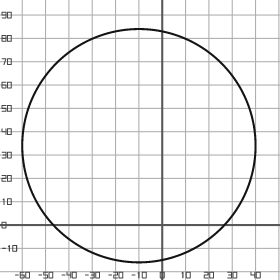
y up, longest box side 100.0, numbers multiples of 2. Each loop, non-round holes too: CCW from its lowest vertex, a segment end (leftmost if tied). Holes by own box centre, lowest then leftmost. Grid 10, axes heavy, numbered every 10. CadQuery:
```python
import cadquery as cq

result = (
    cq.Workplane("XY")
    .moveTo(-10.0, 34.0)
    .circle(50.0)
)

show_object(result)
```